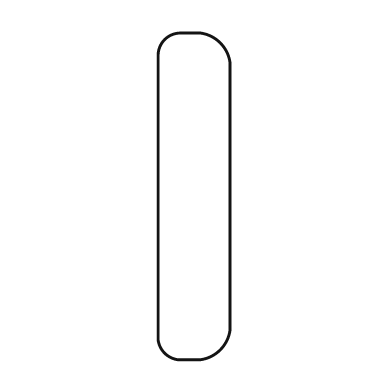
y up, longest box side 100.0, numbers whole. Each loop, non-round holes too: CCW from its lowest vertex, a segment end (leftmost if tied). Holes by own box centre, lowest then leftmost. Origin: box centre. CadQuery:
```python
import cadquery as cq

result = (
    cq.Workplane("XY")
    .moveTo(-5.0, -50.0)
    .lineTo(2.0, -50.0)
    .threePointArc((8.0, -47.0), (11.0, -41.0))
    .lineTo(11.0, 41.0)
    .threePointArc((8.0, 47.0), (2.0, 50.0))
    .lineTo(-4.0, 50.0)
    .threePointArc((-9.0, 48.0), (-11.0, 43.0))
    .lineTo(-11.0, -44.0)
    .threePointArc((-9.0, -48.0), (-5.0, -50.0))
    .close()
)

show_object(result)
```